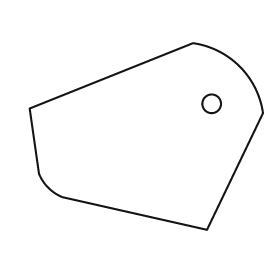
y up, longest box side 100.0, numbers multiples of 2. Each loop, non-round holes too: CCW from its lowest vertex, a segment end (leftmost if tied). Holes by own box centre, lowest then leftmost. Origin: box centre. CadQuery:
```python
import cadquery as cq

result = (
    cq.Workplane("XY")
    .moveTo(26.0, -40.0)
    .lineTo(50.0, 10.0)
    .threePointArc((40.0, 30.0), (20.0, 40.0))
    .lineTo(-50.0, 12.0)
    .lineTo(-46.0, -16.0)
    .threePointArc((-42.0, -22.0), (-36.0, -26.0))
    .close()
    .moveTo(28.0, 14.0)
    .circle(4.0)
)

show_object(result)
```